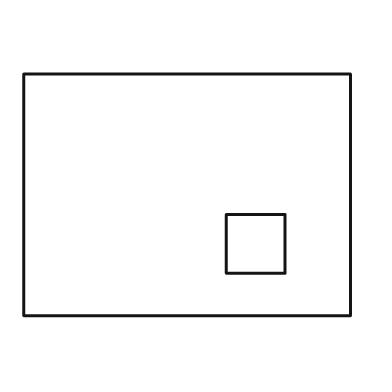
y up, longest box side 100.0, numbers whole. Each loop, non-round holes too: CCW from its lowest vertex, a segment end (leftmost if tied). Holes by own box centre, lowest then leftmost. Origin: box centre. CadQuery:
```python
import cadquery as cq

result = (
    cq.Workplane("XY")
    .moveTo(-50.0, -37.0)
    .lineTo(50.0, -37.0)
    .lineTo(50.0, 37.0)
    .lineTo(-50.0, 37.0)
    .close()
    .moveTo(12.0, -24.0)
    .lineTo(30.0, -24.0)
    .lineTo(30.0, -6.0)
    .lineTo(12.0, -6.0)
    .close()
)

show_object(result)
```